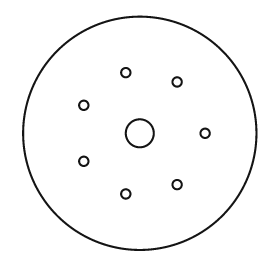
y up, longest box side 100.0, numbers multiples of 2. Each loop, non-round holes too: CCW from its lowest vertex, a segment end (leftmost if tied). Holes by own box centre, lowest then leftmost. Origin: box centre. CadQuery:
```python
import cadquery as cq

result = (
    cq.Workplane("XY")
    .moveTo(0.0, 0.0)
    .circle(50.0)
    .moveTo(-6.0, -26.0)
    .circle(2.0)
    .moveTo(16.0, -22.0)
    .circle(2.0)
    .moveTo(-24.0, -12.0)
    .circle(2.0)
    .moveTo(0.0, 0.0)
    .circle(6.0)
    .moveTo(28.0, 0.0)
    .circle(2.0)
    .moveTo(-24.0, 12.0)
    .circle(2.0)
    .moveTo(16.0, 22.0)
    .circle(2.0)
    .moveTo(-6.0, 26.0)
    .circle(2.0)
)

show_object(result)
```